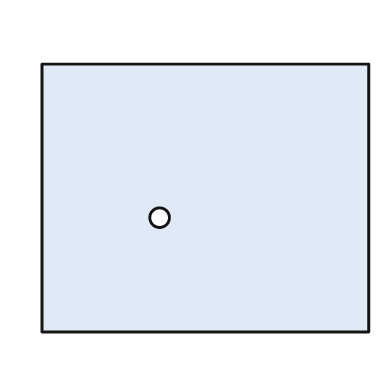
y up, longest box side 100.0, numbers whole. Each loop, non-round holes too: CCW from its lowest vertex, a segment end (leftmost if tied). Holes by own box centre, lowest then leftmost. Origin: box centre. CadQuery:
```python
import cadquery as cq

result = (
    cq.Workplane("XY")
    .moveTo(-50.0, -41.0)
    .lineTo(50.0, -41.0)
    .lineTo(50.0, 41.0)
    .lineTo(-50.0, 41.0)
    .close()
    .moveTo(-14.0, -6.0)
    .circle(3.0)
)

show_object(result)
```